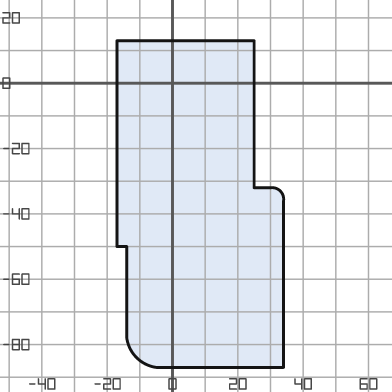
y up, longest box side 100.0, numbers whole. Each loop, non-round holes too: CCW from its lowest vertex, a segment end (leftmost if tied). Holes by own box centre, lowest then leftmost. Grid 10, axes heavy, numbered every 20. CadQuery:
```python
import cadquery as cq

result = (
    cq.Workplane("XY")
    .moveTo(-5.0, -87.0)
    .lineTo(34.0, -87.0)
    .lineTo(34.0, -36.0)
    .threePointArc((33.0, -33.0), (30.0, -32.0))
    .lineTo(25.0, -32.0)
    .lineTo(25.0, 13.0)
    .lineTo(-17.0, 13.0)
    .lineTo(-17.0, -50.0)
    .lineTo(-14.0, -50.0)
    .lineTo(-14.0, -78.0)
    .threePointArc((-11.0, -84.0), (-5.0, -87.0))
    .close()
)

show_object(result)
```